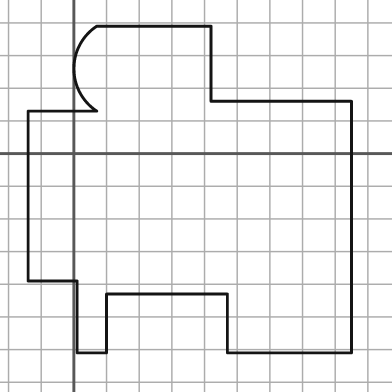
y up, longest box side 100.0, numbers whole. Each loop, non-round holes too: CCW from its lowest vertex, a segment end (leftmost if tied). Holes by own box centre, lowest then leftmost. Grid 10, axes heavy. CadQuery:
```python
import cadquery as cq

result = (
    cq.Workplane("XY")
    .moveTo(1.0, -61.0)
    .lineTo(10.0, -61.0)
    .lineTo(10.0, -43.0)
    .lineTo(47.0, -43.0)
    .lineTo(47.0, -61.0)
    .lineTo(85.0, -61.0)
    .lineTo(85.0, 16.0)
    .lineTo(42.0, 16.0)
    .lineTo(42.0, 39.0)
    .lineTo(7.0, 39.0)
    .threePointArc((0.0, 26.0), (7.0, 13.0))
    .lineTo(-14.0, 13.0)
    .lineTo(-14.0, -39.0)
    .lineTo(1.0, -39.0)
    .close()
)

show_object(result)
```